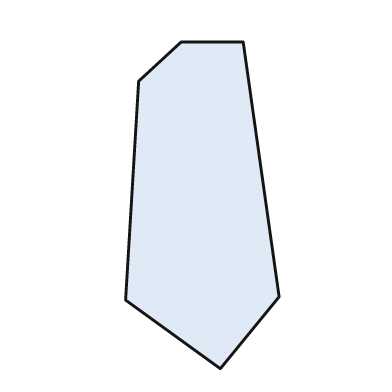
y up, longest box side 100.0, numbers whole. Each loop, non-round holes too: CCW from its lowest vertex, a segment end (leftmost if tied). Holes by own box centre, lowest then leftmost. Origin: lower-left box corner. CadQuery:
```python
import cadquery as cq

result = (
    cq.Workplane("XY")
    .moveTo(29.0, 0.0)
    .lineTo(47.0, 22.0)
    .lineTo(36.0, 100.0)
    .lineTo(17.0, 100.0)
    .lineTo(4.0, 88.0)
    .lineTo(0.0, 21.0)
    .close()
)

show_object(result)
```